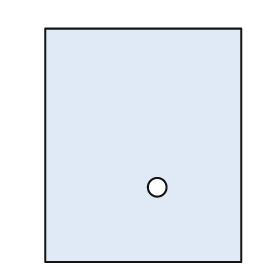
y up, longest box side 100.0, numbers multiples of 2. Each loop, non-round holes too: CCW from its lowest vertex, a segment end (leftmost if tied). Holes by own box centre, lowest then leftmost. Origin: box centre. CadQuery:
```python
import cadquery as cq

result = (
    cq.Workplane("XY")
    .moveTo(-42.0, -50.0)
    .lineTo(42.0, -50.0)
    .lineTo(42.0, 50.0)
    .lineTo(-42.0, 50.0)
    .close()
    .moveTo(6.0, -18.0)
    .circle(4.0)
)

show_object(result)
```